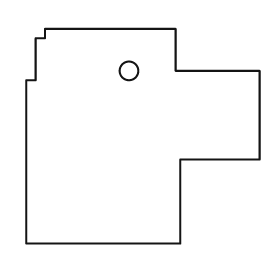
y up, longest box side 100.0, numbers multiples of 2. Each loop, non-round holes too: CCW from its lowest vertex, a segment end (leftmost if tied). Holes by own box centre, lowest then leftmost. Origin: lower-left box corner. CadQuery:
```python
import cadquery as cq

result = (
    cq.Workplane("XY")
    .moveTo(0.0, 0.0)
    .lineTo(66.0, 0.0)
    .lineTo(66.0, 36.0)
    .lineTo(100.0, 36.0)
    .lineTo(100.0, 74.0)
    .lineTo(64.0, 74.0)
    .lineTo(64.0, 92.0)
    .lineTo(8.0, 92.0)
    .lineTo(8.0, 88.0)
    .lineTo(4.0, 88.0)
    .lineTo(4.0, 70.0)
    .lineTo(0.0, 70.0)
    .close()
    .moveTo(44.0, 74.0)
    .circle(4.0)
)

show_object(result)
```